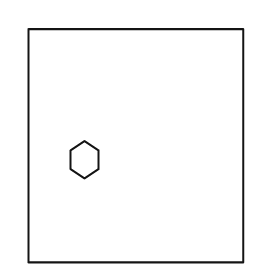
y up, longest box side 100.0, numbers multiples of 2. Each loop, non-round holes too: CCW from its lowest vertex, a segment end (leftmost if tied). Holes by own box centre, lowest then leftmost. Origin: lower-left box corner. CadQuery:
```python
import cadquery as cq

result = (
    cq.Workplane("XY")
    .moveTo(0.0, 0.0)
    .lineTo(92.0, 0.0)
    .lineTo(92.0, 100.0)
    .lineTo(0.0, 100.0)
    .close()
    .moveTo(24.0, 36.0)
    .lineTo(30.0, 40.0)
    .lineTo(30.0, 48.0)
    .lineTo(24.0, 52.0)
    .lineTo(18.0, 48.0)
    .lineTo(18.0, 40.0)
    .close()
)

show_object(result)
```